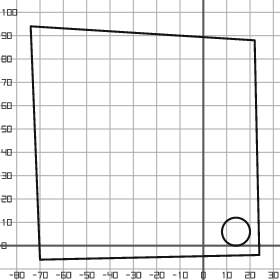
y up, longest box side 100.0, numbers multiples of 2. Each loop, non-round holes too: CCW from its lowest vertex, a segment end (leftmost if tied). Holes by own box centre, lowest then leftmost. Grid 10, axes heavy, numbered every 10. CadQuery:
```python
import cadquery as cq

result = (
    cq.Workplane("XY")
    .moveTo(-70.0, -6.0)
    .lineTo(24.0, -4.0)
    .lineTo(22.0, 88.0)
    .lineTo(-74.0, 94.0)
    .close()
    .moveTo(14.0, 6.0)
    .circle(6.0)
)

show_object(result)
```